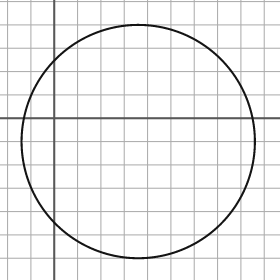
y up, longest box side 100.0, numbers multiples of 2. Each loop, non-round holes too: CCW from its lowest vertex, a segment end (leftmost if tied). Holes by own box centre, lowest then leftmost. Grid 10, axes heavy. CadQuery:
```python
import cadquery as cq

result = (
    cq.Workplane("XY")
    .moveTo(36.0, -10.0)
    .circle(50.0)
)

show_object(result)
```